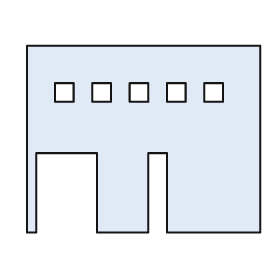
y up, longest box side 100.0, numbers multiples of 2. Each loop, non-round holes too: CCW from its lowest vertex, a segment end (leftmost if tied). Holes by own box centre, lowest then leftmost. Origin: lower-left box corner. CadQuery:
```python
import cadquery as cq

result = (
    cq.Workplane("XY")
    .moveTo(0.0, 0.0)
    .lineTo(4.0, 0.0)
    .lineTo(4.0, 34.0)
    .lineTo(30.0, 34.0)
    .lineTo(30.0, 0.0)
    .lineTo(52.0, 0.0)
    .lineTo(52.0, 34.0)
    .lineTo(60.0, 34.0)
    .lineTo(60.0, 0.0)
    .lineTo(100.0, 0.0)
    .lineTo(100.0, 80.0)
    .lineTo(0.0, 80.0)
    .close()
    .moveTo(12.0, 56.0)
    .lineTo(20.0, 56.0)
    .lineTo(20.0, 64.0)
    .lineTo(12.0, 64.0)
    .close()
    .moveTo(28.0, 56.0)
    .lineTo(36.0, 56.0)
    .lineTo(36.0, 64.0)
    .lineTo(28.0, 64.0)
    .close()
    .moveTo(44.0, 56.0)
    .lineTo(52.0, 56.0)
    .lineTo(52.0, 64.0)
    .lineTo(44.0, 64.0)
    .close()
    .moveTo(60.0, 56.0)
    .lineTo(68.0, 56.0)
    .lineTo(68.0, 64.0)
    .lineTo(60.0, 64.0)
    .close()
    .moveTo(76.0, 56.0)
    .lineTo(84.0, 56.0)
    .lineTo(84.0, 64.0)
    .lineTo(76.0, 64.0)
    .close()
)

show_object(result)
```